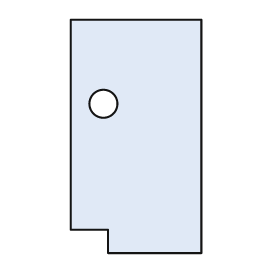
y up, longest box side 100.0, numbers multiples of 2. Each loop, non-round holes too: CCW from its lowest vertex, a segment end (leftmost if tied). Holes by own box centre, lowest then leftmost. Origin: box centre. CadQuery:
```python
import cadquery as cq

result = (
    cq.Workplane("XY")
    .moveTo(-12.0, -50.0)
    .lineTo(28.0, -50.0)
    .lineTo(28.0, 50.0)
    .lineTo(-28.0, 50.0)
    .lineTo(-28.0, -40.0)
    .lineTo(-12.0, -40.0)
    .close()
    .moveTo(-14.0, 14.0)
    .circle(6.0)
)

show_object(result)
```